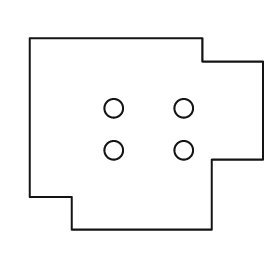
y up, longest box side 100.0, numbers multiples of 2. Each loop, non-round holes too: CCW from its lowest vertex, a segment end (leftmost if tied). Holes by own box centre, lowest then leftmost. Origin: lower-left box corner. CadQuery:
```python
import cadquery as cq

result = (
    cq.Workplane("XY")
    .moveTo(18.0, 0.0)
    .lineTo(78.0, 0.0)
    .lineTo(78.0, 30.0)
    .lineTo(100.0, 30.0)
    .lineTo(100.0, 72.0)
    .lineTo(74.0, 72.0)
    .lineTo(74.0, 82.0)
    .lineTo(0.0, 82.0)
    .lineTo(0.0, 14.0)
    .lineTo(18.0, 14.0)
    .close()
    .moveTo(36.0, 34.0)
    .circle(4.0)
    .moveTo(66.0, 34.0)
    .circle(4.0)
    .moveTo(36.0, 52.0)
    .circle(4.0)
    .moveTo(66.0, 52.0)
    .circle(4.0)
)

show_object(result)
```